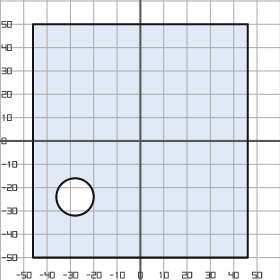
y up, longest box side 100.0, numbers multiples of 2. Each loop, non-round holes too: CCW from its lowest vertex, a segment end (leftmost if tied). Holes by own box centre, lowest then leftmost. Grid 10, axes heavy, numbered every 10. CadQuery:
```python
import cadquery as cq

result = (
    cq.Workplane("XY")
    .moveTo(-46.0, -50.0)
    .lineTo(46.0, -50.0)
    .lineTo(46.0, 50.0)
    .lineTo(-46.0, 50.0)
    .close()
    .moveTo(-28.0, -24.0)
    .circle(8.0)
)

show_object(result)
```